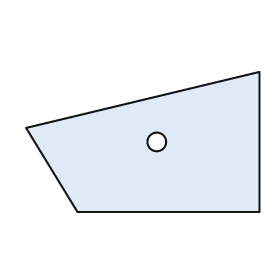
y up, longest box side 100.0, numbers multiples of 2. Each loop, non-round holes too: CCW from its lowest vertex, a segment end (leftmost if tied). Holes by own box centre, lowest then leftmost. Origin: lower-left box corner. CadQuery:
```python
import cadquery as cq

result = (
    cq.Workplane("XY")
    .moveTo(22.0, 0.0)
    .lineTo(100.0, 0.0)
    .lineTo(100.0, 60.0)
    .lineTo(0.0, 36.0)
    .close()
    .moveTo(56.0, 30.0)
    .circle(4.0)
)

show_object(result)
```